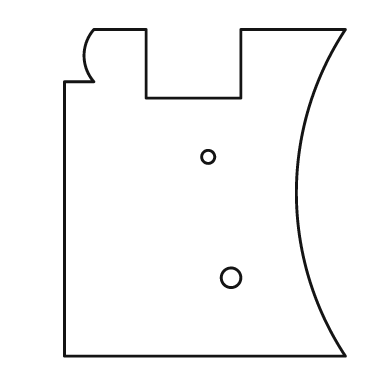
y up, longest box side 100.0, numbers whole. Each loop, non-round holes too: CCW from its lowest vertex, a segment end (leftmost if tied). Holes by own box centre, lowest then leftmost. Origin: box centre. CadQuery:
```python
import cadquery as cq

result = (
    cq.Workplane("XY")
    .moveTo(-43.0, -50.0)
    .lineTo(43.0, -50.0)
    .threePointArc((28.0, 0.0), (43.0, 50.0))
    .lineTo(11.0, 50.0)
    .lineTo(11.0, 29.0)
    .lineTo(-18.0, 29.0)
    .lineTo(-18.0, 50.0)
    .lineTo(-34.0, 50.0)
    .threePointArc((-37.0, 42.0), (-34.0, 34.0))
    .lineTo(-43.0, 34.0)
    .close()
    .moveTo(8.0, -26.0)
    .circle(3.0)
    .moveTo(1.0, 11.0)
    .circle(2.0)
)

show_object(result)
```